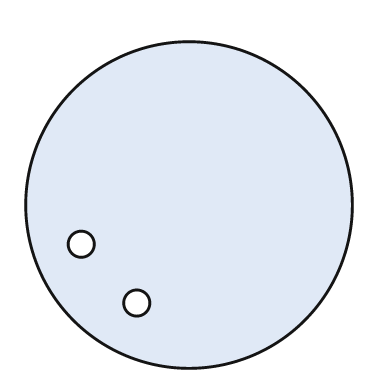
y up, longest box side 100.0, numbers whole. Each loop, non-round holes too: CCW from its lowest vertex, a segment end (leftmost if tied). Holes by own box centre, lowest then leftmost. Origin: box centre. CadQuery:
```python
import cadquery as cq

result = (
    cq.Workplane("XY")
    .moveTo(0.0, 0.0)
    .circle(50.0)
    .moveTo(-16.0, -30.0)
    .circle(4.0)
    .moveTo(-33.0, -12.0)
    .circle(4.0)
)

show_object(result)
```